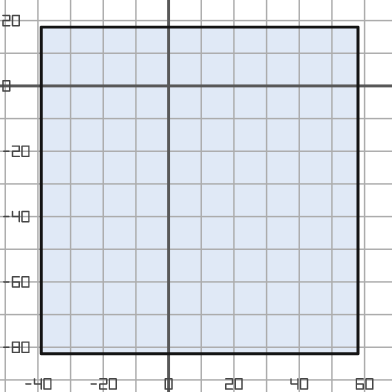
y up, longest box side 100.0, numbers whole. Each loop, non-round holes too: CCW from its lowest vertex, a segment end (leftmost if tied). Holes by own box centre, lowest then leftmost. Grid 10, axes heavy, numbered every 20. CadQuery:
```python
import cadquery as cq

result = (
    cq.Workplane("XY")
    .moveTo(-39.0, -82.0)
    .lineTo(58.0, -82.0)
    .lineTo(58.0, 18.0)
    .lineTo(-39.0, 18.0)
    .close()
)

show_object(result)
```